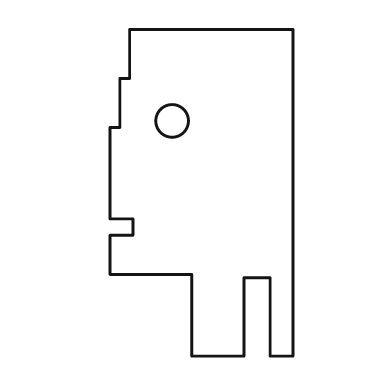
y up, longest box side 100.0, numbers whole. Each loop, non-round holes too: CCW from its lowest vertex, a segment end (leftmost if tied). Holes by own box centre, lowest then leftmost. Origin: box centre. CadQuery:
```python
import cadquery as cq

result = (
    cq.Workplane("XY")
    .moveTo(-3.0, -50.0)
    .lineTo(13.0, -50.0)
    .lineTo(13.0, -26.0)
    .lineTo(21.0, -26.0)
    .lineTo(21.0, -50.0)
    .lineTo(28.0, -50.0)
    .lineTo(28.0, 50.0)
    .lineTo(-22.0, 50.0)
    .lineTo(-22.0, 35.0)
    .lineTo(-25.0, 35.0)
    .lineTo(-25.0, 20.0)
    .lineTo(-28.0, 20.0)
    .lineTo(-28.0, -8.0)
    .lineTo(-21.0, -8.0)
    .lineTo(-21.0, -13.0)
    .lineTo(-28.0, -13.0)
    .lineTo(-28.0, -25.0)
    .lineTo(-3.0, -25.0)
    .close()
    .moveTo(-9.0, 22.0)
    .circle(5.0)
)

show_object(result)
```